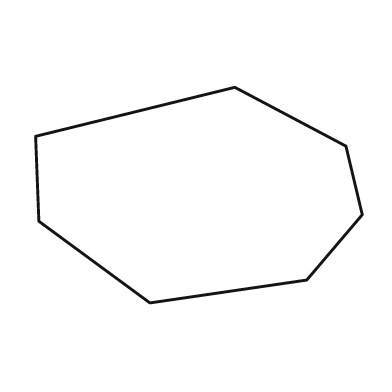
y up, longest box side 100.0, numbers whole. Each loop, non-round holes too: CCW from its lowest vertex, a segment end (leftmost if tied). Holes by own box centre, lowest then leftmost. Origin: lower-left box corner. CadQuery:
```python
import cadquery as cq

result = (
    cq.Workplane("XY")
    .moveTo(35.0, 0.0)
    .lineTo(83.0, 7.0)
    .lineTo(100.0, 27.0)
    .lineTo(95.0, 48.0)
    .lineTo(61.0, 66.0)
    .lineTo(0.0, 51.0)
    .lineTo(1.0, 25.0)
    .close()
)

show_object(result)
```